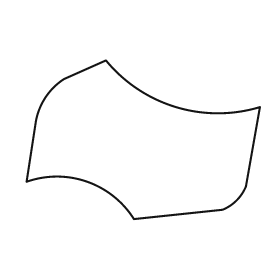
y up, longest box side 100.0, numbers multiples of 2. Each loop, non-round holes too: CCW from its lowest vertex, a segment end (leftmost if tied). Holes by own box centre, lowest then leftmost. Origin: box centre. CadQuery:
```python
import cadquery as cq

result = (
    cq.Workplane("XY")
    .moveTo(-4.0, -34.0)
    .lineTo(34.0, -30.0)
    .threePointArc((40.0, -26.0), (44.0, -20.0))
    .lineTo(50.0, 14.0)
    .threePointArc((14.0, 14.0), (-16.0, 34.0))
    .lineTo(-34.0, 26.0)
    .threePointArc((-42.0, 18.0), (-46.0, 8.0))
    .lineTo(-50.0, -18.0)
    .threePointArc((-24.0, -18.0), (-4.0, -34.0))
    .close()
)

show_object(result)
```